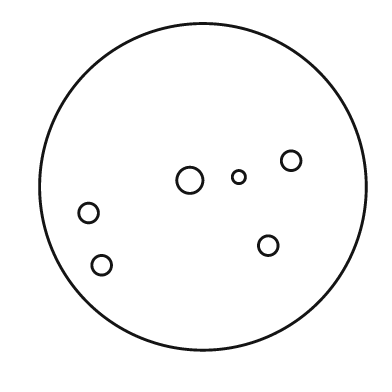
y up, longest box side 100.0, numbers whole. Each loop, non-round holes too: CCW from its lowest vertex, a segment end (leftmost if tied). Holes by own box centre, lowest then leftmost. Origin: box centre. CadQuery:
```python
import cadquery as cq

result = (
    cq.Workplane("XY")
    .moveTo(0.0, 0.0)
    .circle(50.0)
    .moveTo(-31.0, -24.0)
    .circle(3.0)
    .moveTo(20.0, -18.0)
    .circle(3.0)
    .moveTo(-35.0, -8.0)
    .circle(3.0)
    .moveTo(-4.0, 2.0)
    .circle(4.0)
    .moveTo(11.0, 3.0)
    .circle(2.0)
    .moveTo(27.0, 8.0)
    .circle(3.0)
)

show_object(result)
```